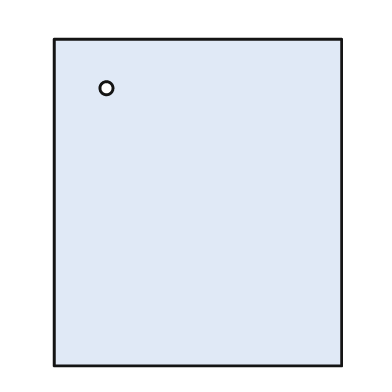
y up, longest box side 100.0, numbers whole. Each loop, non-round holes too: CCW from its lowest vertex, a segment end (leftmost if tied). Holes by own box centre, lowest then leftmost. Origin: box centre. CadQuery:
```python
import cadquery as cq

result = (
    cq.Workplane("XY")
    .moveTo(-44.0, -50.0)
    .lineTo(44.0, -50.0)
    .lineTo(44.0, 50.0)
    .lineTo(-44.0, 50.0)
    .close()
    .moveTo(-28.0, 35.0)
    .circle(2.0)
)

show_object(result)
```